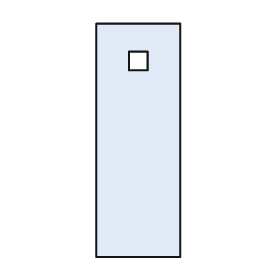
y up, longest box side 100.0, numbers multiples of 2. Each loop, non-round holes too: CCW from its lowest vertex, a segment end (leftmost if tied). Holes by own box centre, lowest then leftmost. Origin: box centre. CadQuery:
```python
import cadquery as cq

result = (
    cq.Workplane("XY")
    .moveTo(-18.0, -50.0)
    .lineTo(18.0, -50.0)
    .lineTo(18.0, 50.0)
    .lineTo(-18.0, 50.0)
    .close()
    .moveTo(-4.0, 30.0)
    .lineTo(4.0, 30.0)
    .lineTo(4.0, 38.0)
    .lineTo(-4.0, 38.0)
    .close()
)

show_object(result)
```